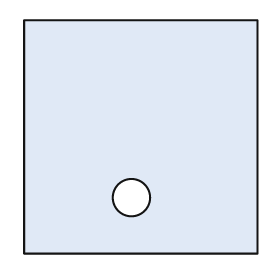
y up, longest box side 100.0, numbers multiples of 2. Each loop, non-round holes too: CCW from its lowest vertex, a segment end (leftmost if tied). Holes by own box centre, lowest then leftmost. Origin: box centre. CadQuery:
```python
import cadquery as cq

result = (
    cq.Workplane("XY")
    .moveTo(-50.0, -50.0)
    .lineTo(50.0, -50.0)
    .lineTo(50.0, 50.0)
    .lineTo(-50.0, 50.0)
    .close()
    .moveTo(-4.0, -26.0)
    .circle(8.0)
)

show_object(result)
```